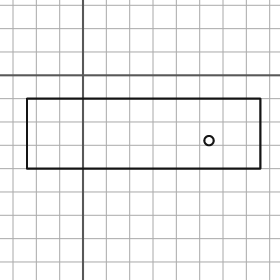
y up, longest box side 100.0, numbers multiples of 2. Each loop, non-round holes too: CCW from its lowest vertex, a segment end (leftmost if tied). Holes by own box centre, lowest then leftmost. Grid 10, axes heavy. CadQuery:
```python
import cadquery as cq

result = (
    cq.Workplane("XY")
    .moveTo(-24.0, -40.0)
    .lineTo(76.0, -40.0)
    .lineTo(76.0, -10.0)
    .lineTo(-24.0, -10.0)
    .close()
    .moveTo(54.0, -28.0)
    .circle(2.0)
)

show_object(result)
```